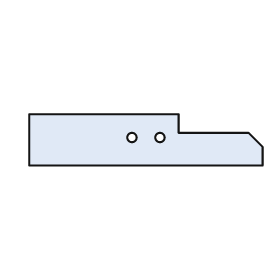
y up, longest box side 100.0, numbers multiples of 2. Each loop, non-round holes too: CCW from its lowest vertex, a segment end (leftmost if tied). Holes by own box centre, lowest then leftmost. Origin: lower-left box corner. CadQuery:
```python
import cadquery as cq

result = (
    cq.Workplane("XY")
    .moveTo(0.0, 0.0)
    .lineTo(100.0, 0.0)
    .lineTo(100.0, 8.0)
    .lineTo(94.0, 14.0)
    .lineTo(64.0, 14.0)
    .lineTo(64.0, 22.0)
    .lineTo(0.0, 22.0)
    .close()
    .moveTo(44.0, 12.0)
    .circle(2.0)
    .moveTo(56.0, 12.0)
    .circle(2.0)
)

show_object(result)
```